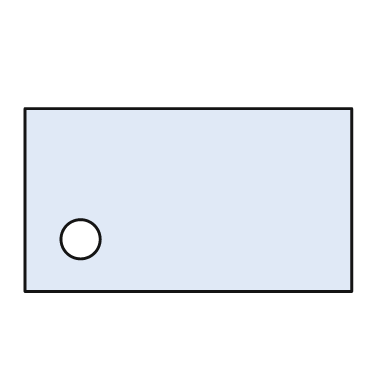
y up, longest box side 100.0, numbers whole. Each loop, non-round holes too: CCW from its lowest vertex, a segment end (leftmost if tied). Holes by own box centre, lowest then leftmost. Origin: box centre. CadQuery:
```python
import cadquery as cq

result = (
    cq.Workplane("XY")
    .moveTo(-50.0, -28.0)
    .lineTo(50.0, -28.0)
    .lineTo(50.0, 28.0)
    .lineTo(-50.0, 28.0)
    .close()
    .moveTo(-33.0, -12.0)
    .circle(6.0)
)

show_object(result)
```